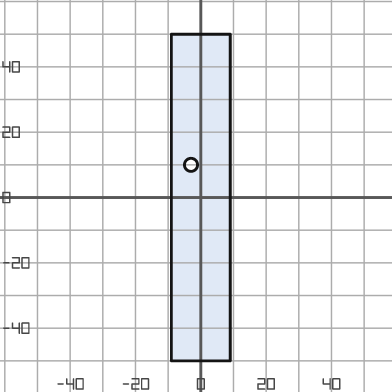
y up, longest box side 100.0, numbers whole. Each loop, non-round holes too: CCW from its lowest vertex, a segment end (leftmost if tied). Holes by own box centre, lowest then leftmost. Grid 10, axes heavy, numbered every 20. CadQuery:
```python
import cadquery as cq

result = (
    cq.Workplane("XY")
    .moveTo(-9.0, -50.0)
    .lineTo(9.0, -50.0)
    .lineTo(9.0, 50.0)
    .lineTo(-9.0, 50.0)
    .close()
    .moveTo(-3.0, 10.0)
    .circle(2.0)
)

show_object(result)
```